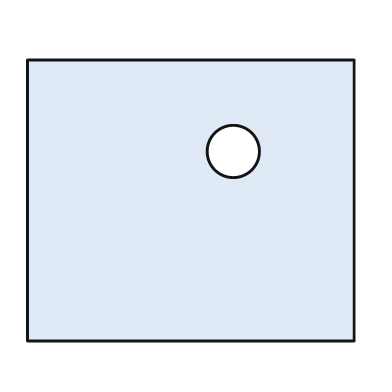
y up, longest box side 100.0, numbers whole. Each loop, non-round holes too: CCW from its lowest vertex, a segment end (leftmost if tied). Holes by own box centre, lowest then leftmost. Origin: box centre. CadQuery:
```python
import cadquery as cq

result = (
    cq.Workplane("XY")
    .moveTo(-50.0, -43.0)
    .lineTo(50.0, -43.0)
    .lineTo(50.0, 43.0)
    .lineTo(-50.0, 43.0)
    .close()
    .moveTo(13.0, 15.0)
    .circle(8.0)
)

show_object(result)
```